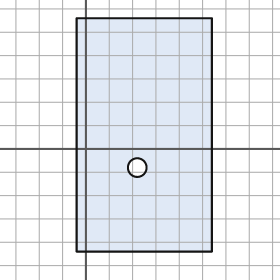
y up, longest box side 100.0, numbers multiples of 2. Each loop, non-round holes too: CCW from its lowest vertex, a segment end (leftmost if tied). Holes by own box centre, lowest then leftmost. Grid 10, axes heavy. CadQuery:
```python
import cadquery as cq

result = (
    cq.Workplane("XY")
    .moveTo(-4.0, -44.0)
    .lineTo(54.0, -44.0)
    .lineTo(54.0, 56.0)
    .lineTo(-4.0, 56.0)
    .close()
    .moveTo(22.0, -8.0)
    .circle(4.0)
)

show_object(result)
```